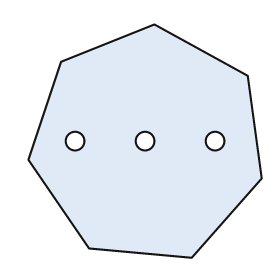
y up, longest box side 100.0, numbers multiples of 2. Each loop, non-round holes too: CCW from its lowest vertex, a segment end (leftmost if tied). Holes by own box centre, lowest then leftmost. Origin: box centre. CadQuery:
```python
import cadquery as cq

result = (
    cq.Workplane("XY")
    .moveTo(20.0, -50.0)
    .lineTo(50.0, -16.0)
    .lineTo(44.0, 28.0)
    .lineTo(4.0, 50.0)
    .lineTo(-36.0, 34.0)
    .lineTo(-50.0, -8.0)
    .lineTo(-24.0, -46.0)
    .close()
    .moveTo(-30.0, 0.0)
    .circle(4.0)
    .moveTo(0.0, 0.0)
    .circle(4.0)
    .moveTo(30.0, 0.0)
    .circle(4.0)
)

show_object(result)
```